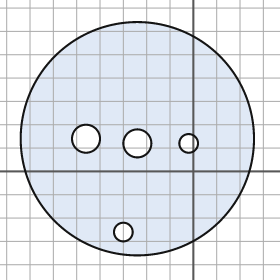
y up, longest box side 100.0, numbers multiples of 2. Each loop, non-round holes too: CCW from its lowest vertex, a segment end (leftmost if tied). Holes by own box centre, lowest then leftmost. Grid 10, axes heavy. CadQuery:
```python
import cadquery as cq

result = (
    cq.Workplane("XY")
    .moveTo(-24.0, 14.0)
    .circle(50.0)
    .moveTo(-30.0, -26.0)
    .circle(4.0)
    .moveTo(-24.0, 12.0)
    .circle(6.0)
    .moveTo(-2.0, 12.0)
    .circle(4.0)
    .moveTo(-46.0, 14.0)
    .circle(6.0)
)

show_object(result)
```